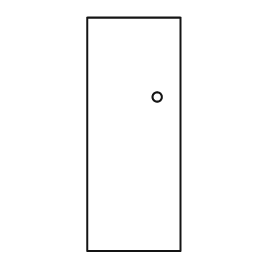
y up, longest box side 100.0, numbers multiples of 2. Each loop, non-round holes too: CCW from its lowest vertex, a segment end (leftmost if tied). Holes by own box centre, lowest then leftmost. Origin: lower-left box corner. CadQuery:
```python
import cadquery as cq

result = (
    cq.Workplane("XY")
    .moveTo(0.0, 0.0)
    .lineTo(40.0, 0.0)
    .lineTo(40.0, 100.0)
    .lineTo(0.0, 100.0)
    .close()
    .moveTo(30.0, 66.0)
    .circle(2.0)
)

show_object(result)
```